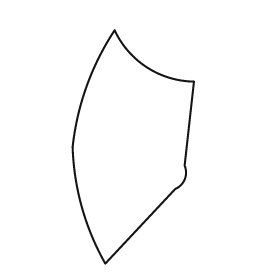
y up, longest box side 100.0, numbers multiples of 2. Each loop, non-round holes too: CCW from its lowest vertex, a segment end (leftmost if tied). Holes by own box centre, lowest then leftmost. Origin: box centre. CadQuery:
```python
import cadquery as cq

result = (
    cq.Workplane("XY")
    .moveTo(-12.0, -50.0)
    .lineTo(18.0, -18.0)
    .threePointArc((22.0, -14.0), (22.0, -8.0))
    .lineTo(26.0, 28.0)
    .threePointArc((6.0, 34.0), (-8.0, 50.0))
    .threePointArc((-20.0, 26.0), (-26.0, 0.0))
    .threePointArc((-22.0, -26.0), (-12.0, -50.0))
    .close()
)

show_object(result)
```